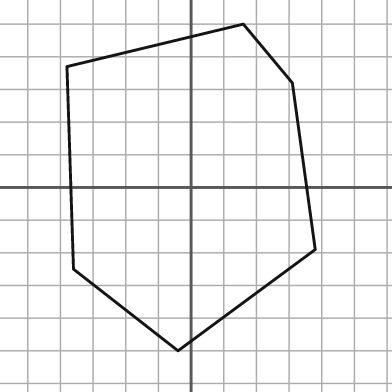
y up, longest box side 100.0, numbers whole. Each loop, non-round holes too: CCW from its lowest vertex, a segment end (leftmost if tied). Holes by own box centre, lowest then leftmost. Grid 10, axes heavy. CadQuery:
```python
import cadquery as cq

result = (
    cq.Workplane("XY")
    .moveTo(-4.0, -50.0)
    .lineTo(38.0, -19.0)
    .lineTo(31.0, 32.0)
    .lineTo(16.0, 50.0)
    .lineTo(-38.0, 37.0)
    .lineTo(-36.0, -25.0)
    .close()
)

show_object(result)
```